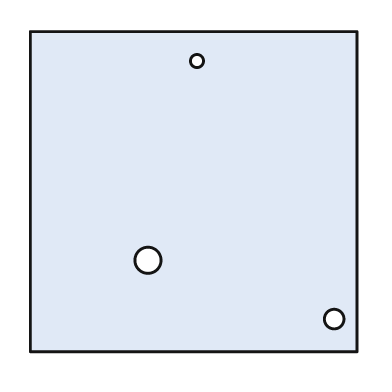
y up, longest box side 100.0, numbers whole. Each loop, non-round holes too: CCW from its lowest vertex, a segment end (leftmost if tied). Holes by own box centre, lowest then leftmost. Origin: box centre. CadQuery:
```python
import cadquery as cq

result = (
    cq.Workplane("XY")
    .moveTo(-50.0, -49.0)
    .lineTo(50.0, -49.0)
    .lineTo(50.0, 49.0)
    .lineTo(-50.0, 49.0)
    .close()
    .moveTo(43.0, -39.0)
    .circle(3.0)
    .moveTo(-14.0, -21.0)
    .circle(4.0)
    .moveTo(1.0, 40.0)
    .circle(2.0)
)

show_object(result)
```